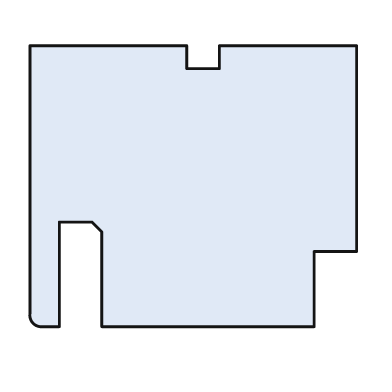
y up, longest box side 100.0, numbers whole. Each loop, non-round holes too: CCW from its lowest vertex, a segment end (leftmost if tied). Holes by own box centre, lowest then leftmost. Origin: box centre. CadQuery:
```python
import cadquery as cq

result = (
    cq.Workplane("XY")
    .moveTo(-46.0, -43.0)
    .lineTo(-41.0, -43.0)
    .lineTo(-41.0, -11.0)
    .lineTo(-31.0, -11.0)
    .lineTo(-28.0, -14.0)
    .lineTo(-28.0, -43.0)
    .lineTo(37.0, -43.0)
    .lineTo(37.0, -20.0)
    .lineTo(50.0, -20.0)
    .lineTo(50.0, 43.0)
    .lineTo(8.0, 43.0)
    .lineTo(8.0, 36.0)
    .lineTo(-2.0, 36.0)
    .lineTo(-2.0, 43.0)
    .lineTo(-50.0, 43.0)
    .lineTo(-50.0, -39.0)
    .threePointArc((-49.0, -42.0), (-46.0, -43.0))
    .close()
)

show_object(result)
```